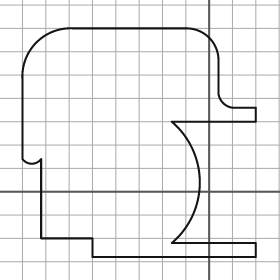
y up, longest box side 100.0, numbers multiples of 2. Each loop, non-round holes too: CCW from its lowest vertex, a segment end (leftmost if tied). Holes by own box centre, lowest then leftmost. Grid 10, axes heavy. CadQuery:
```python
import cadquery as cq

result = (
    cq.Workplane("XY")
    .moveTo(-50.0, -28.0)
    .lineTo(20.0, -28.0)
    .lineTo(20.0, -22.0)
    .lineTo(-16.0, -22.0)
    .threePointArc((-4.0, 4.0), (-16.0, 30.0))
    .lineTo(20.0, 30.0)
    .lineTo(20.0, 36.0)
    .lineTo(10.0, 36.0)
    .threePointArc((6.0, 38.0), (4.0, 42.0))
    .lineTo(4.0, 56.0)
    .threePointArc((0.0, 66.0), (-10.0, 70.0))
    .lineTo(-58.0, 70.0)
    .threePointArc((-74.0, 64.0), (-80.0, 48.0))
    .lineTo(-80.0, 14.0)
    .threePointArc((-76.0, 12.0), (-72.0, 14.0))
    .lineTo(-72.0, -20.0)
    .lineTo(-50.0, -20.0)
    .close()
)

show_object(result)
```